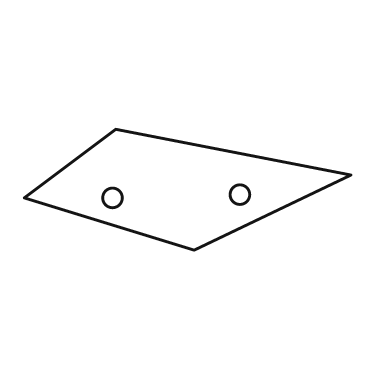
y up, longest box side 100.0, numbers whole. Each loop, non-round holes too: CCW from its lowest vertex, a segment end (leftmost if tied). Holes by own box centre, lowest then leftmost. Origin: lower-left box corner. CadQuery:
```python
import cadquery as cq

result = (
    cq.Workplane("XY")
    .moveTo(52.0, 0.0)
    .lineTo(100.0, 23.0)
    .lineTo(28.0, 37.0)
    .lineTo(0.0, 16.0)
    .close()
    .moveTo(27.0, 16.0)
    .circle(3.0)
    .moveTo(66.0, 17.0)
    .circle(3.0)
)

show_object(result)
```